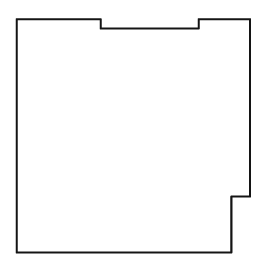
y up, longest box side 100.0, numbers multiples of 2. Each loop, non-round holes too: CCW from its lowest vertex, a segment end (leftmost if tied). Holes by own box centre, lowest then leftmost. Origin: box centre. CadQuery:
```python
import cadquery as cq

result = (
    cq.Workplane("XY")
    .moveTo(-50.0, -50.0)
    .lineTo(42.0, -50.0)
    .lineTo(42.0, -26.0)
    .lineTo(50.0, -26.0)
    .lineTo(50.0, 50.0)
    .lineTo(28.0, 50.0)
    .lineTo(28.0, 46.0)
    .lineTo(-14.0, 46.0)
    .lineTo(-14.0, 50.0)
    .lineTo(-50.0, 50.0)
    .close()
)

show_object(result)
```